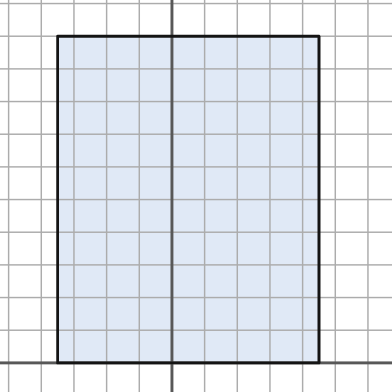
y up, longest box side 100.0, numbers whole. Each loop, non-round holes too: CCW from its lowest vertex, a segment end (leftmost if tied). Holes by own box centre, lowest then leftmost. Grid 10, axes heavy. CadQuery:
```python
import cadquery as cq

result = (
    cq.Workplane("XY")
    .moveTo(-35.0, 0.0)
    .lineTo(45.0, 0.0)
    .lineTo(45.0, 100.0)
    .lineTo(-35.0, 100.0)
    .close()
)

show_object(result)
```